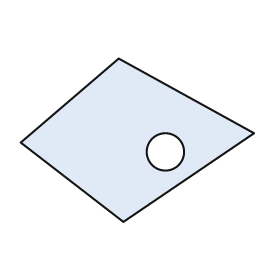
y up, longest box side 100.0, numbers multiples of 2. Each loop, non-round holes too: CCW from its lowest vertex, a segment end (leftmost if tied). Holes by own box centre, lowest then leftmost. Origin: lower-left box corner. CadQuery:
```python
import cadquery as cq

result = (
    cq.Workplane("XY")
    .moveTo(44.0, 0.0)
    .lineTo(100.0, 38.0)
    .lineTo(42.0, 70.0)
    .lineTo(0.0, 34.0)
    .close()
    .moveTo(62.0, 30.0)
    .circle(8.0)
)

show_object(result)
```